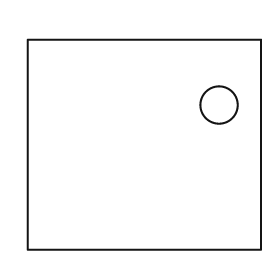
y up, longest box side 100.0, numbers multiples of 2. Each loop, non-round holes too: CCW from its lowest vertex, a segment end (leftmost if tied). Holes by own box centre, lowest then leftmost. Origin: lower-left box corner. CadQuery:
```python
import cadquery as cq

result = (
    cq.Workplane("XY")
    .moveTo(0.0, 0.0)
    .lineTo(100.0, 0.0)
    .lineTo(100.0, 90.0)
    .lineTo(0.0, 90.0)
    .close()
    .moveTo(82.0, 62.0)
    .circle(8.0)
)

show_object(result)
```